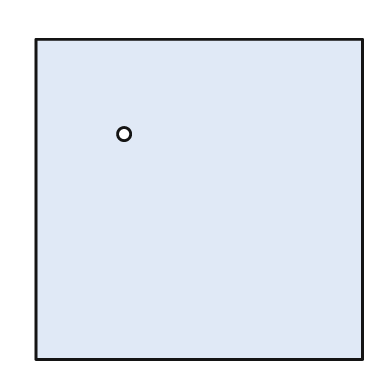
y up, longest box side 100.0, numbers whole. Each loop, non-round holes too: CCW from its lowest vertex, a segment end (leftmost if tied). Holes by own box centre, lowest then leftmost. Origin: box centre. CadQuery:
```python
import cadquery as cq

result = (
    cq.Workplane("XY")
    .moveTo(-50.0, -49.0)
    .lineTo(50.0, -49.0)
    .lineTo(50.0, 49.0)
    .lineTo(-50.0, 49.0)
    .close()
    .moveTo(-23.0, 20.0)
    .circle(2.0)
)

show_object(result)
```